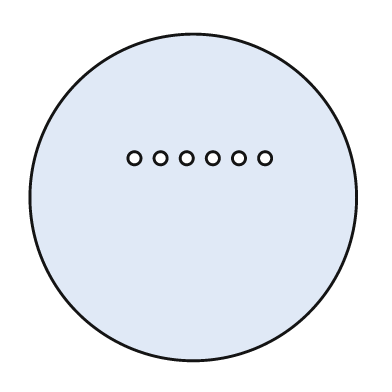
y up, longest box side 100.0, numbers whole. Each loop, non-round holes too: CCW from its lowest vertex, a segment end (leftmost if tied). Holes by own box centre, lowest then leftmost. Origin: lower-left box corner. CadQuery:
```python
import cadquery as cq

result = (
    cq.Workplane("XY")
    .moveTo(50.0, 50.0)
    .circle(50.0)
    .moveTo(32.0, 62.0)
    .circle(2.0)
    .moveTo(40.0, 62.0)
    .circle(2.0)
    .moveTo(48.0, 62.0)
    .circle(2.0)
    .moveTo(56.0, 62.0)
    .circle(2.0)
    .moveTo(64.0, 62.0)
    .circle(2.0)
    .moveTo(72.0, 62.0)
    .circle(2.0)
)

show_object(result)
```